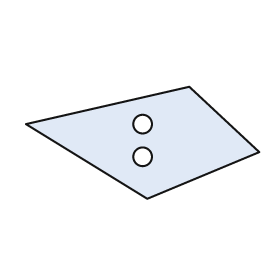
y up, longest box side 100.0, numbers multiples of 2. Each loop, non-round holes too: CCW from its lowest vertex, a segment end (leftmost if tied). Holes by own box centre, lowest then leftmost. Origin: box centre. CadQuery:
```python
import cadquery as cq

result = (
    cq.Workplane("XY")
    .moveTo(2.0, -24.0)
    .lineTo(50.0, -4.0)
    .lineTo(20.0, 24.0)
    .lineTo(-50.0, 8.0)
    .close()
    .moveTo(0.0, -6.0)
    .circle(4.0)
    .moveTo(0.0, 8.0)
    .circle(4.0)
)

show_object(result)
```